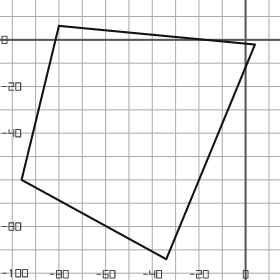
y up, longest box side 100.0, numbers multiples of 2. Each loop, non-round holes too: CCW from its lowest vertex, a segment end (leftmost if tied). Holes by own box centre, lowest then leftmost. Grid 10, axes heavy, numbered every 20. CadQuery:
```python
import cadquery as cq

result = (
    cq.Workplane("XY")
    .moveTo(-34.0, -94.0)
    .lineTo(4.0, -2.0)
    .lineTo(-80.0, 6.0)
    .lineTo(-96.0, -60.0)
    .close()
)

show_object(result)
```